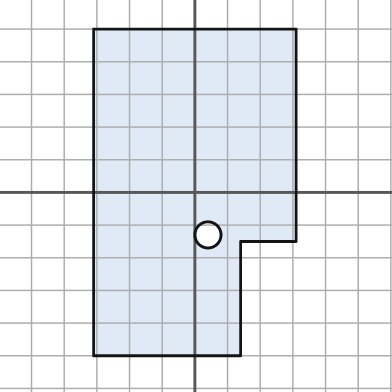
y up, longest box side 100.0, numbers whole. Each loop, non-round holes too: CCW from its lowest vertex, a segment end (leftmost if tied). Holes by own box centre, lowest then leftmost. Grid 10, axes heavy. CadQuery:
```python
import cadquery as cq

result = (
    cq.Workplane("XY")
    .moveTo(-31.0, -50.0)
    .lineTo(14.0, -50.0)
    .lineTo(14.0, -15.0)
    .lineTo(31.0, -15.0)
    .lineTo(31.0, 50.0)
    .lineTo(-31.0, 50.0)
    .close()
    .moveTo(4.0, -13.0)
    .circle(4.0)
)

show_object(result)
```